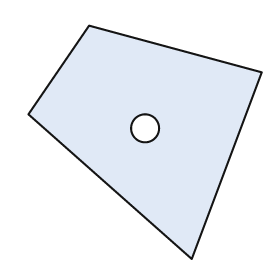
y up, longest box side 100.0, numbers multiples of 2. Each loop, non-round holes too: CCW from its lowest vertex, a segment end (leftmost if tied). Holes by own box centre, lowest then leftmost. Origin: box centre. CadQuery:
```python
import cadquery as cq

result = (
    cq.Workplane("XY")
    .moveTo(20.0, -50.0)
    .lineTo(50.0, 30.0)
    .lineTo(-24.0, 50.0)
    .lineTo(-50.0, 12.0)
    .close()
    .moveTo(0.0, 6.0)
    .circle(6.0)
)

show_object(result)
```